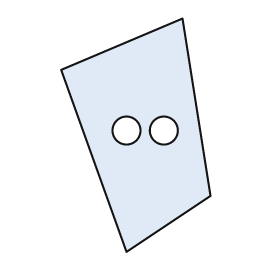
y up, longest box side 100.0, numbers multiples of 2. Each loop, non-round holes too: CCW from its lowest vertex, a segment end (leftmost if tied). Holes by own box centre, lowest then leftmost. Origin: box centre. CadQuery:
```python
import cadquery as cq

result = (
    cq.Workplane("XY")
    .moveTo(-4.0, -50.0)
    .lineTo(32.0, -26.0)
    .lineTo(20.0, 50.0)
    .lineTo(-32.0, 28.0)
    .close()
    .moveTo(-4.0, 2.0)
    .circle(6.0)
    .moveTo(12.0, 2.0)
    .circle(6.0)
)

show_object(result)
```